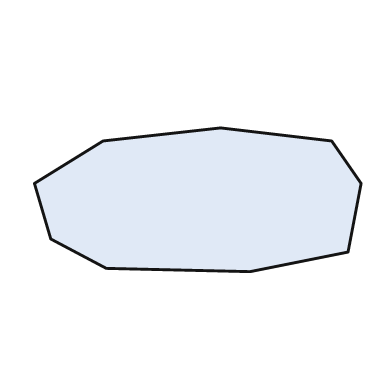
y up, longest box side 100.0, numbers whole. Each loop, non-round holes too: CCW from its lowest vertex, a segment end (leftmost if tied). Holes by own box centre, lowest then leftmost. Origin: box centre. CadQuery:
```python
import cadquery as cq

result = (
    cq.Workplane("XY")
    .moveTo(16.0, -22.0)
    .lineTo(46.0, -16.0)
    .lineTo(50.0, 5.0)
    .lineTo(41.0, 18.0)
    .lineTo(7.0, 22.0)
    .lineTo(-29.0, 18.0)
    .lineTo(-50.0, 5.0)
    .lineTo(-45.0, -12.0)
    .lineTo(-28.0, -21.0)
    .close()
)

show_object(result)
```